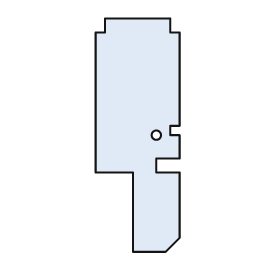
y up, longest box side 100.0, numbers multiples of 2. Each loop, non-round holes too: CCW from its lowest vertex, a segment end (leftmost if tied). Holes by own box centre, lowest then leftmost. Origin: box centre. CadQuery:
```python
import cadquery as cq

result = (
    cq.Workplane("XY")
    .moveTo(-2.0, -50.0)
    .lineTo(12.0, -50.0)
    .lineTo(18.0, -44.0)
    .lineTo(18.0, -16.0)
    .lineTo(8.0, -16.0)
    .lineTo(8.0, -10.0)
    .lineTo(18.0, -10.0)
    .lineTo(18.0, 0.0)
    .lineTo(14.0, 0.0)
    .lineTo(14.0, 4.0)
    .lineTo(18.0, 4.0)
    .lineTo(18.0, 44.0)
    .lineTo(14.0, 44.0)
    .lineTo(14.0, 50.0)
    .lineTo(-14.0, 50.0)
    .lineTo(-14.0, 44.0)
    .lineTo(-18.0, 44.0)
    .lineTo(-18.0, -16.0)
    .lineTo(-2.0, -16.0)
    .close()
    .moveTo(8.0, 0.0)
    .circle(2.0)
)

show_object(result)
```